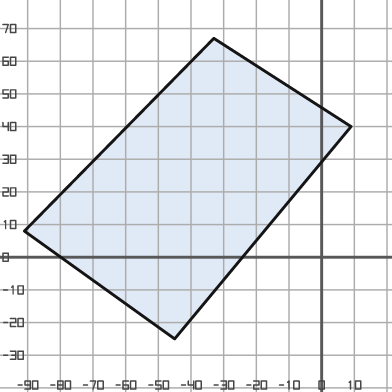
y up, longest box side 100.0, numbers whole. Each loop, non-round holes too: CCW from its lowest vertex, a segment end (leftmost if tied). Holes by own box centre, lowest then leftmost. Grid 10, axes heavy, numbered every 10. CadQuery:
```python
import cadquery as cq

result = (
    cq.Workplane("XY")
    .moveTo(-45.0, -25.0)
    .lineTo(9.0, 40.0)
    .lineTo(-33.0, 67.0)
    .lineTo(-91.0, 8.0)
    .close()
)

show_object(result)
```